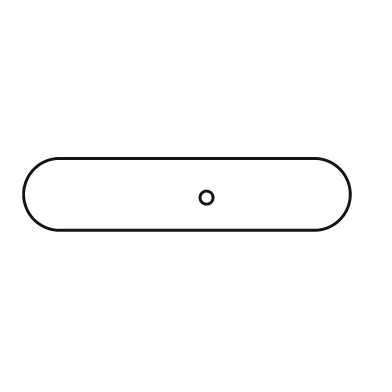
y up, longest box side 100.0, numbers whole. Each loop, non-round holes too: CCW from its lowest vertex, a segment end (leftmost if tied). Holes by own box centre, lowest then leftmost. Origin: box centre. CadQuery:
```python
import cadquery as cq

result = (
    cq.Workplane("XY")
    .moveTo(-39.0, -11.0)
    .lineTo(39.0, -11.0)
    .threePointArc((50.0, 0.0), (39.0, 11.0))
    .lineTo(-39.0, 11.0)
    .threePointArc((-50.0, 0.0), (-39.0, -11.0))
    .close()
    .moveTo(6.0, -1.0)
    .circle(2.0)
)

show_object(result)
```